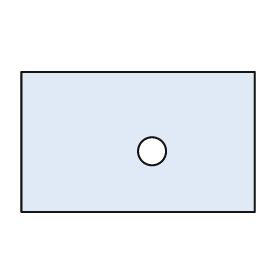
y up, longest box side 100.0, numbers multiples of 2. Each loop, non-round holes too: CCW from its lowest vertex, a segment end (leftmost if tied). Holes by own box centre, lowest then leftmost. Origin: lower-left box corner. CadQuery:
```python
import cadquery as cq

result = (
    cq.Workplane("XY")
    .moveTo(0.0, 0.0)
    .lineTo(100.0, 0.0)
    .lineTo(100.0, 60.0)
    .lineTo(0.0, 60.0)
    .close()
    .moveTo(56.0, 26.0)
    .circle(6.0)
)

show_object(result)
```